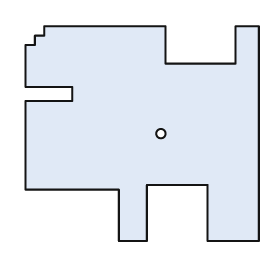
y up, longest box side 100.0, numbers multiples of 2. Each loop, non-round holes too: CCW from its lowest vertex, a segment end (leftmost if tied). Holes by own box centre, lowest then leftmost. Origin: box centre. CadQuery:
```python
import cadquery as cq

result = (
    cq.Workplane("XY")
    .moveTo(-10.0, -46.0)
    .lineTo(2.0, -46.0)
    .lineTo(2.0, -22.0)
    .lineTo(28.0, -22.0)
    .lineTo(28.0, -46.0)
    .lineTo(50.0, -46.0)
    .lineTo(50.0, 46.0)
    .lineTo(40.0, 46.0)
    .lineTo(40.0, 30.0)
    .lineTo(10.0, 30.0)
    .lineTo(10.0, 46.0)
    .lineTo(-42.0, 46.0)
    .lineTo(-42.0, 42.0)
    .lineTo(-46.0, 42.0)
    .lineTo(-46.0, 38.0)
    .lineTo(-50.0, 38.0)
    .lineTo(-50.0, 20.0)
    .lineTo(-30.0, 20.0)
    .lineTo(-30.0, 14.0)
    .lineTo(-50.0, 14.0)
    .lineTo(-50.0, -24.0)
    .lineTo(-10.0, -24.0)
    .close()
    .moveTo(8.0, 0.0)
    .circle(2.0)
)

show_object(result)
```